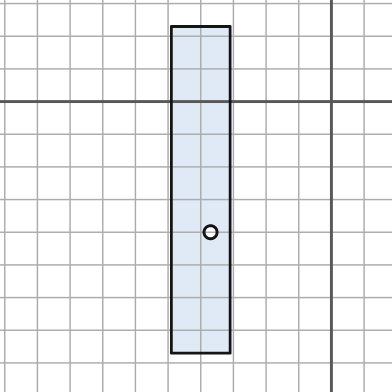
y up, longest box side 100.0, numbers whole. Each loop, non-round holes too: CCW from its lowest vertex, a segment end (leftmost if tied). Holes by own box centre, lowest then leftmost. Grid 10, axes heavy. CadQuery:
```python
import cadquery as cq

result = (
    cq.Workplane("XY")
    .moveTo(-49.0, -77.0)
    .lineTo(-31.0, -77.0)
    .lineTo(-31.0, 23.0)
    .lineTo(-49.0, 23.0)
    .close()
    .moveTo(-37.0, -40.0)
    .circle(2.0)
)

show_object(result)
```